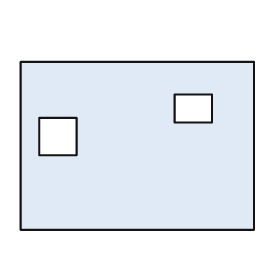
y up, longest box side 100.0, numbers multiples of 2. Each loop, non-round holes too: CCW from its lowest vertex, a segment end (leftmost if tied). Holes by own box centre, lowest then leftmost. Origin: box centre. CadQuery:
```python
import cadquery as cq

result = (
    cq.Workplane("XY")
    .moveTo(-50.0, -36.0)
    .lineTo(50.0, -36.0)
    .lineTo(50.0, 36.0)
    .lineTo(-50.0, 36.0)
    .close()
    .moveTo(-42.0, -4.0)
    .lineTo(-26.0, -4.0)
    .lineTo(-26.0, 12.0)
    .lineTo(-42.0, 12.0)
    .close()
    .moveTo(16.0, 10.0)
    .lineTo(32.0, 10.0)
    .lineTo(32.0, 22.0)
    .lineTo(16.0, 22.0)
    .close()
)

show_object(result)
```